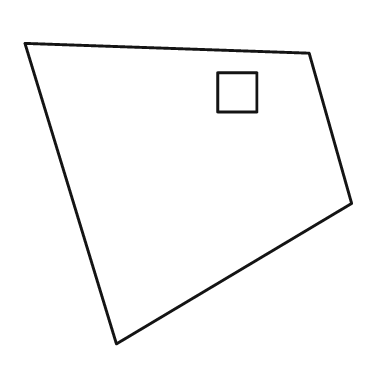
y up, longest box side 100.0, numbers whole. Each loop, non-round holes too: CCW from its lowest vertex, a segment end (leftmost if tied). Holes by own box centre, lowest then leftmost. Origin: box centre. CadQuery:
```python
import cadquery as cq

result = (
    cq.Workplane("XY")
    .moveTo(-22.0, -46.0)
    .lineTo(50.0, -3.0)
    .lineTo(37.0, 43.0)
    .lineTo(-50.0, 46.0)
    .close()
    .moveTo(9.0, 25.0)
    .lineTo(21.0, 25.0)
    .lineTo(21.0, 37.0)
    .lineTo(9.0, 37.0)
    .close()
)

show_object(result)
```